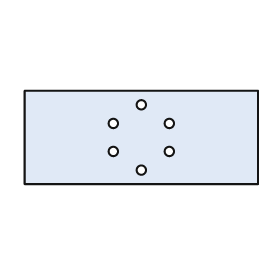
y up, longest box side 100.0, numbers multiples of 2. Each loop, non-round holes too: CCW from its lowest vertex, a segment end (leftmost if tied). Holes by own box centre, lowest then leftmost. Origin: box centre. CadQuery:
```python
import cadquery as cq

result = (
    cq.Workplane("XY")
    .moveTo(-50.0, -20.0)
    .lineTo(50.0, -20.0)
    .lineTo(50.0, 20.0)
    .lineTo(-50.0, 20.0)
    .close()
    .moveTo(0.0, -14.0)
    .circle(2.0)
    .moveTo(-12.0, -6.0)
    .circle(2.0)
    .moveTo(12.0, -6.0)
    .circle(2.0)
    .moveTo(-12.0, 6.0)
    .circle(2.0)
    .moveTo(12.0, 6.0)
    .circle(2.0)
    .moveTo(0.0, 14.0)
    .circle(2.0)
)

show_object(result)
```